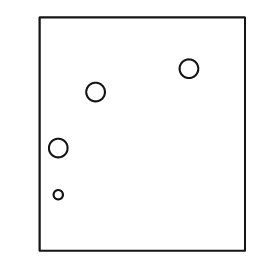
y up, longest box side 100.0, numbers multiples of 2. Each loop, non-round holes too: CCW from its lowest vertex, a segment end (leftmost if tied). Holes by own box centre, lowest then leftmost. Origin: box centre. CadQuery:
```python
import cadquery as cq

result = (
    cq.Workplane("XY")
    .moveTo(-44.0, -50.0)
    .lineTo(44.0, -50.0)
    .lineTo(44.0, 50.0)
    .lineTo(-44.0, 50.0)
    .close()
    .moveTo(-36.0, -26.0)
    .circle(2.0)
    .moveTo(-36.0, -6.0)
    .circle(4.0)
    .moveTo(-20.0, 18.0)
    .circle(4.0)
    .moveTo(20.0, 28.0)
    .circle(4.0)
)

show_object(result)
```